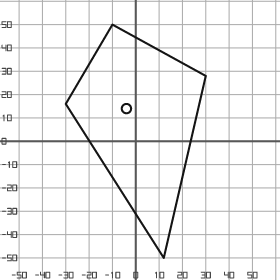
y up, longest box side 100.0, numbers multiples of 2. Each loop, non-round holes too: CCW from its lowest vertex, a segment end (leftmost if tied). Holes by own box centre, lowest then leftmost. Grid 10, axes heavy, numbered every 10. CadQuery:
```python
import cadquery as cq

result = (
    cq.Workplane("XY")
    .moveTo(12.0, -50.0)
    .lineTo(30.0, 28.0)
    .lineTo(-10.0, 50.0)
    .lineTo(-30.0, 16.0)
    .close()
    .moveTo(-4.0, 14.0)
    .circle(2.0)
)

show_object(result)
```